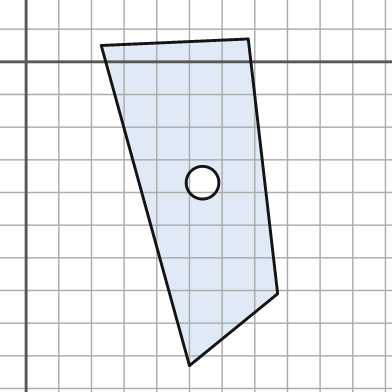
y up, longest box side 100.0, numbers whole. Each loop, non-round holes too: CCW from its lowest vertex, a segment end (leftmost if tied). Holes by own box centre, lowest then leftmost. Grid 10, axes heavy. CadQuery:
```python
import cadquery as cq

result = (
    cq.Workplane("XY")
    .moveTo(50.0, -93.0)
    .lineTo(77.0, -71.0)
    .lineTo(68.0, 7.0)
    .lineTo(23.0, 5.0)
    .close()
    .moveTo(54.0, -37.0)
    .circle(5.0)
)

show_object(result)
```